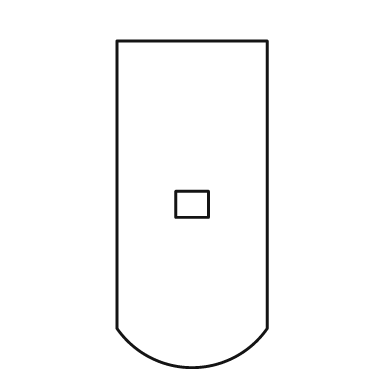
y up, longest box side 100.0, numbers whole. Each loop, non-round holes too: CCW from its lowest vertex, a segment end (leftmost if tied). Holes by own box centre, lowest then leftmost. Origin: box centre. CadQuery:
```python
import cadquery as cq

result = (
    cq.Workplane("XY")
    .moveTo(-23.0, -38.0)
    .threePointArc((0.0, -50.0), (23.0, -38.0))
    .lineTo(23.0, 50.0)
    .lineTo(-23.0, 50.0)
    .close()
    .moveTo(-5.0, -4.0)
    .lineTo(5.0, -4.0)
    .lineTo(5.0, 4.0)
    .lineTo(-5.0, 4.0)
    .close()
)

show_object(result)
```